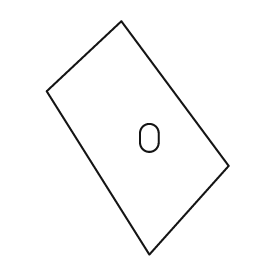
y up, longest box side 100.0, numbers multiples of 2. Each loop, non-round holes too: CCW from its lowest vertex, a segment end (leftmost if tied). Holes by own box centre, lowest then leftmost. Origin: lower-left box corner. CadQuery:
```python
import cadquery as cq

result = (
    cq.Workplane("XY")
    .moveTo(44.0, 0.0)
    .lineTo(78.0, 38.0)
    .lineTo(32.0, 100.0)
    .lineTo(0.0, 70.0)
    .close()
    .moveTo(40.0, 48.0)
    .threePointArc((44.0, 44.0), (48.0, 48.0))
    .lineTo(48.0, 52.0)
    .threePointArc((44.0, 56.0), (40.0, 52.0))
    .close()
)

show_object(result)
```